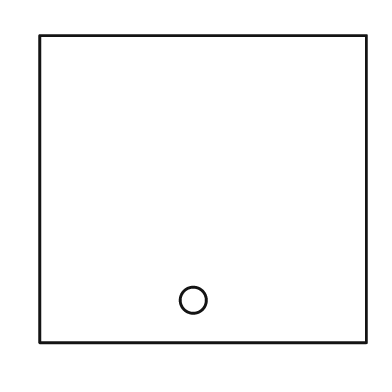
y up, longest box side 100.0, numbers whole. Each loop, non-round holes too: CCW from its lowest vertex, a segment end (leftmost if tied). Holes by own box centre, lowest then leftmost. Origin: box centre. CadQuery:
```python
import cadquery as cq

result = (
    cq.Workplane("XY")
    .moveTo(-50.0, -47.0)
    .lineTo(50.0, -47.0)
    .lineTo(50.0, 47.0)
    .lineTo(-50.0, 47.0)
    .close()
    .moveTo(-3.0, -34.0)
    .circle(4.0)
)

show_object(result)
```